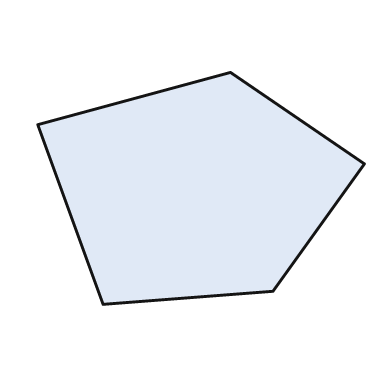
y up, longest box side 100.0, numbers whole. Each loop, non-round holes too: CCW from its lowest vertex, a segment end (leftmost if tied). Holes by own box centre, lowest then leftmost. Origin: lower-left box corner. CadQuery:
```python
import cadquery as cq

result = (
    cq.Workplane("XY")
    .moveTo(20.0, 0.0)
    .lineTo(72.0, 4.0)
    .lineTo(100.0, 43.0)
    .lineTo(59.0, 71.0)
    .lineTo(0.0, 55.0)
    .close()
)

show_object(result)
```